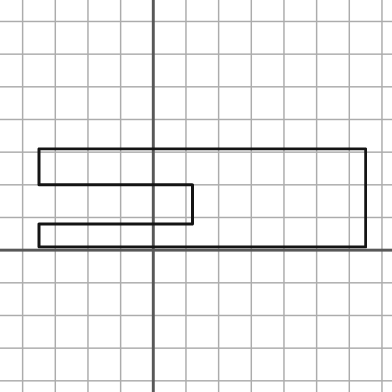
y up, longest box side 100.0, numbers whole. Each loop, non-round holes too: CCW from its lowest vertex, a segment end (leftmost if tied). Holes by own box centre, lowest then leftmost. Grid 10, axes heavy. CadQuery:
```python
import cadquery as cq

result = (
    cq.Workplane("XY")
    .moveTo(-35.0, 1.0)
    .lineTo(65.0, 1.0)
    .lineTo(65.0, 31.0)
    .lineTo(-35.0, 31.0)
    .lineTo(-35.0, 20.0)
    .lineTo(12.0, 20.0)
    .lineTo(12.0, 8.0)
    .lineTo(-35.0, 8.0)
    .close()
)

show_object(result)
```